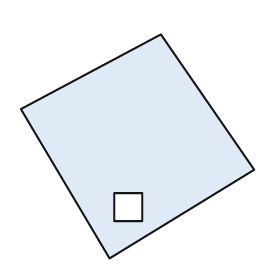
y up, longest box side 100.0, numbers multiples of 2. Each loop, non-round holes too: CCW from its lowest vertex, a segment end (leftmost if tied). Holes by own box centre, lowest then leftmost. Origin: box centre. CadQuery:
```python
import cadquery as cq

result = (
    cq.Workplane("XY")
    .moveTo(-12.0, -48.0)
    .lineTo(50.0, -10.0)
    .lineTo(10.0, 48.0)
    .lineTo(-50.0, 16.0)
    .close()
    .moveTo(-10.0, -32.0)
    .lineTo(2.0, -32.0)
    .lineTo(2.0, -20.0)
    .lineTo(-10.0, -20.0)
    .close()
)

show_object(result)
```